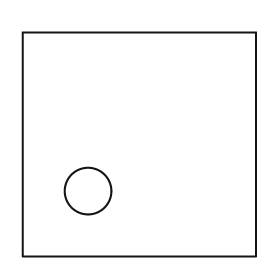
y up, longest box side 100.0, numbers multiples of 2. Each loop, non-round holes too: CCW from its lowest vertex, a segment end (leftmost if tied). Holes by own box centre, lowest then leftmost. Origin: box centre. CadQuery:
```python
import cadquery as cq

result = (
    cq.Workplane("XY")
    .moveTo(-50.0, -48.0)
    .lineTo(50.0, -48.0)
    .lineTo(50.0, 48.0)
    .lineTo(-50.0, 48.0)
    .close()
    .moveTo(-22.0, -20.0)
    .circle(10.0)
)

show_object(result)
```